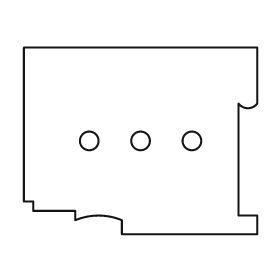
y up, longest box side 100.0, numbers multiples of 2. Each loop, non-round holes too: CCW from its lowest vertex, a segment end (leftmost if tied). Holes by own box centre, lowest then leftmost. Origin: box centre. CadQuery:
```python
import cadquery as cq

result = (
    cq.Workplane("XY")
    .moveTo(-8.0, -40.0)
    .lineTo(50.0, -40.0)
    .lineTo(50.0, -32.0)
    .lineTo(42.0, -32.0)
    .lineTo(42.0, 16.0)
    .threePointArc((46.0, 14.0), (50.0, 16.0))
    .lineTo(50.0, 40.0)
    .lineTo(-50.0, 40.0)
    .lineTo(-50.0, -26.0)
    .lineTo(-46.0, -26.0)
    .lineTo(-46.0, -30.0)
    .lineTo(-28.0, -30.0)
    .lineTo(-28.0, -34.0)
    .threePointArc((-18.0, -32.0), (-8.0, -34.0))
    .close()
    .moveTo(-22.0, 0.0)
    .circle(4.0)
    .moveTo(0.0, 0.0)
    .circle(4.0)
    .moveTo(22.0, 0.0)
    .circle(4.0)
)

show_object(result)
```